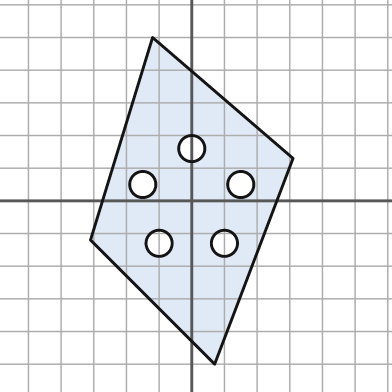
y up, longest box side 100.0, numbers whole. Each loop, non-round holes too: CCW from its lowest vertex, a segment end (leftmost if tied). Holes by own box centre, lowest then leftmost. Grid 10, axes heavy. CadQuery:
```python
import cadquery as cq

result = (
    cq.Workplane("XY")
    .moveTo(7.0, -50.0)
    .lineTo(31.0, 13.0)
    .lineTo(-12.0, 50.0)
    .lineTo(-31.0, -12.0)
    .close()
    .moveTo(-10.0, -13.0)
    .circle(4.0)
    .moveTo(10.0, -13.0)
    .circle(4.0)
    .moveTo(-15.0, 5.0)
    .circle(4.0)
    .moveTo(15.0, 5.0)
    .circle(4.0)
    .moveTo(0.0, 16.0)
    .circle(4.0)
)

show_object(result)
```